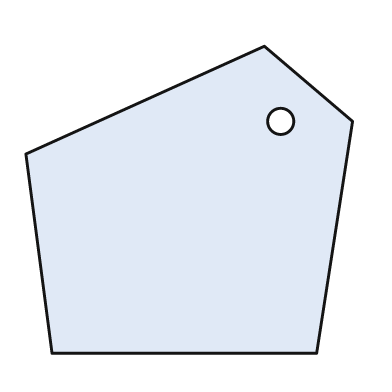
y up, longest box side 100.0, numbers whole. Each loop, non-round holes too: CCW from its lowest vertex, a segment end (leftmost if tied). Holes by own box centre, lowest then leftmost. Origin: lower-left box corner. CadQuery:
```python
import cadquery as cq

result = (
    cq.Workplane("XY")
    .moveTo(8.0, 0.0)
    .lineTo(89.0, 0.0)
    .lineTo(100.0, 71.0)
    .lineTo(73.0, 94.0)
    .lineTo(0.0, 61.0)
    .close()
    .moveTo(78.0, 71.0)
    .circle(4.0)
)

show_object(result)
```